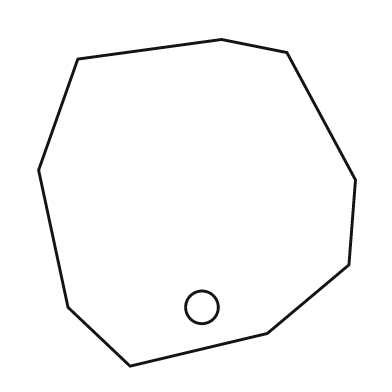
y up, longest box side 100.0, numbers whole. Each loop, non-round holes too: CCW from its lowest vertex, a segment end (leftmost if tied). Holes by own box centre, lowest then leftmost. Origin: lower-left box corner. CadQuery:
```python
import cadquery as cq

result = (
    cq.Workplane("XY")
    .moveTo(28.0, 0.0)
    .lineTo(70.0, 10.0)
    .lineTo(95.0, 31.0)
    .lineTo(97.0, 57.0)
    .lineTo(76.0, 96.0)
    .lineTo(56.0, 100.0)
    .lineTo(12.0, 94.0)
    .lineTo(0.0, 60.0)
    .lineTo(9.0, 18.0)
    .close()
    .moveTo(50.0, 18.0)
    .circle(5.0)
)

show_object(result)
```